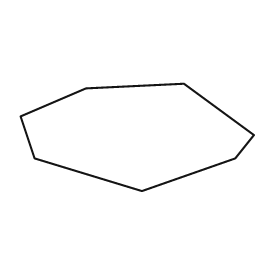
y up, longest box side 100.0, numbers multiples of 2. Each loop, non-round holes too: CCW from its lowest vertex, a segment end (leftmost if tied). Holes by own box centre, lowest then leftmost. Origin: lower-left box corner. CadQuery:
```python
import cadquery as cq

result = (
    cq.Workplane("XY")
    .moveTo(52.0, 0.0)
    .lineTo(92.0, 14.0)
    .lineTo(100.0, 24.0)
    .lineTo(70.0, 46.0)
    .lineTo(28.0, 44.0)
    .lineTo(0.0, 32.0)
    .lineTo(6.0, 14.0)
    .close()
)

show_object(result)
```